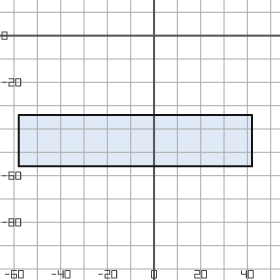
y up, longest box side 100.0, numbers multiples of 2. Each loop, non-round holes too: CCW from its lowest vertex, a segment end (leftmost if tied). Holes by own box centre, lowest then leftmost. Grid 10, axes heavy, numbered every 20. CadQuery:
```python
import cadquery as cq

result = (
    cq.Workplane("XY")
    .moveTo(-58.0, -56.0)
    .lineTo(42.0, -56.0)
    .lineTo(42.0, -34.0)
    .lineTo(-58.0, -34.0)
    .close()
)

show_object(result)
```